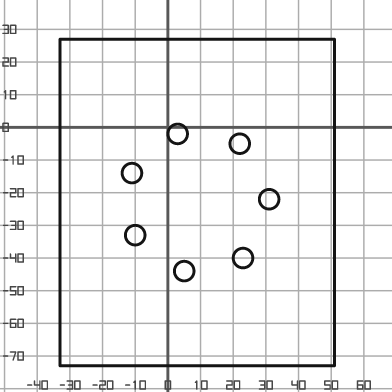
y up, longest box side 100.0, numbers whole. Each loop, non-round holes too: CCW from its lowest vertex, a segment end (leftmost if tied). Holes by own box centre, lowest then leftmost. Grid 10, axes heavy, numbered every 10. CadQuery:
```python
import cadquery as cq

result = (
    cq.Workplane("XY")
    .moveTo(-33.0, -73.0)
    .lineTo(51.0, -73.0)
    .lineTo(51.0, 27.0)
    .lineTo(-33.0, 27.0)
    .close()
    .moveTo(5.0, -44.0)
    .circle(3.0)
    .moveTo(23.0, -40.0)
    .circle(3.0)
    .moveTo(-10.0, -33.0)
    .circle(3.0)
    .moveTo(31.0, -22.0)
    .circle(3.0)
    .moveTo(-11.0, -14.0)
    .circle(3.0)
    .moveTo(22.0, -5.0)
    .circle(3.0)
    .moveTo(3.0, -2.0)
    .circle(3.0)
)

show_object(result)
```